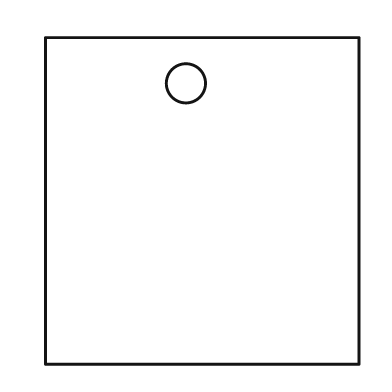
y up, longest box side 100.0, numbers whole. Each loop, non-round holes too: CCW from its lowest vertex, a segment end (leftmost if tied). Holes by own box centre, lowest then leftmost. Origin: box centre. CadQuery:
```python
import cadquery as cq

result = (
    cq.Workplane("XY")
    .moveTo(-48.0, -50.0)
    .lineTo(48.0, -50.0)
    .lineTo(48.0, 50.0)
    .lineTo(-48.0, 50.0)
    .close()
    .moveTo(-5.0, 36.0)
    .circle(6.0)
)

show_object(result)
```